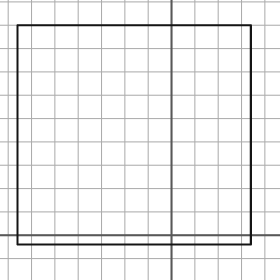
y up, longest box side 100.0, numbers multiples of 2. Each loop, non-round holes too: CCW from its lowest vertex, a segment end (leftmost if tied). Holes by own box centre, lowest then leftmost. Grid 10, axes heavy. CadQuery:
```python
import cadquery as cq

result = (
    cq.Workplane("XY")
    .moveTo(-66.0, -4.0)
    .lineTo(34.0, -4.0)
    .lineTo(34.0, 90.0)
    .lineTo(-66.0, 90.0)
    .close()
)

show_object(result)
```